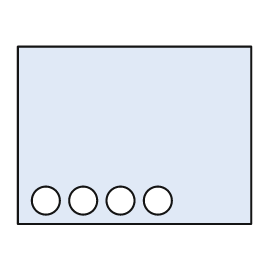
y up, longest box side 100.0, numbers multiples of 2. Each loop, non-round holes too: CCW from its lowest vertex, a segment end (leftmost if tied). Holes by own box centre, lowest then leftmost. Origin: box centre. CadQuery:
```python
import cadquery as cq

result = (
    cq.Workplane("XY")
    .moveTo(-50.0, -38.0)
    .lineTo(50.0, -38.0)
    .lineTo(50.0, 38.0)
    .lineTo(-50.0, 38.0)
    .close()
    .moveTo(-38.0, -28.0)
    .circle(6.0)
    .moveTo(-22.0, -28.0)
    .circle(6.0)
    .moveTo(-6.0, -28.0)
    .circle(6.0)
    .moveTo(10.0, -28.0)
    .circle(6.0)
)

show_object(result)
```